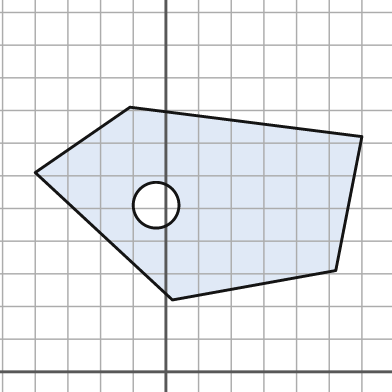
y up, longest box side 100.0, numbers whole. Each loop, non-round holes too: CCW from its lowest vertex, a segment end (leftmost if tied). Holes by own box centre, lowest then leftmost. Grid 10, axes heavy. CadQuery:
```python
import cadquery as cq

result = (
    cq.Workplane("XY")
    .moveTo(2.0, 22.0)
    .lineTo(52.0, 31.0)
    .lineTo(60.0, 72.0)
    .lineTo(-11.0, 81.0)
    .lineTo(-40.0, 61.0)
    .close()
    .moveTo(-3.0, 51.0)
    .circle(7.0)
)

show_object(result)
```